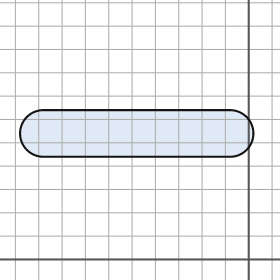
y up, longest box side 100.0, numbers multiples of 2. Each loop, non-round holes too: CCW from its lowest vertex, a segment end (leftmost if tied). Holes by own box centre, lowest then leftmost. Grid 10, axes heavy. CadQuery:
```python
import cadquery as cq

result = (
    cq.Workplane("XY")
    .moveTo(-88.0, 44.0)
    .lineTo(-8.0, 44.0)
    .threePointArc((2.0, 54.0), (-8.0, 64.0))
    .lineTo(-88.0, 64.0)
    .threePointArc((-98.0, 54.0), (-88.0, 44.0))
    .close()
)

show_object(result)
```